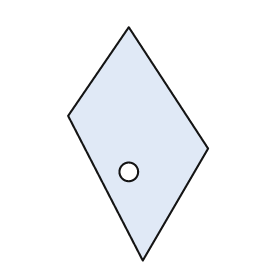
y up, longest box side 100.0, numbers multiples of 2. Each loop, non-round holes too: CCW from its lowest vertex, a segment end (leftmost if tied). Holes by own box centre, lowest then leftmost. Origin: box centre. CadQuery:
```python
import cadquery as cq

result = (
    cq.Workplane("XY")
    .moveTo(2.0, -50.0)
    .lineTo(30.0, -2.0)
    .lineTo(-4.0, 50.0)
    .lineTo(-30.0, 12.0)
    .close()
    .moveTo(-4.0, -12.0)
    .circle(4.0)
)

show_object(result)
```